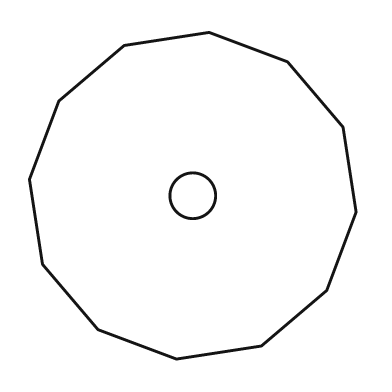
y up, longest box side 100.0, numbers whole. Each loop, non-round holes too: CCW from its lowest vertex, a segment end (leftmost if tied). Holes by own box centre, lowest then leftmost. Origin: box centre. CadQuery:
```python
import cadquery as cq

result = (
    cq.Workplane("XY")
    .moveTo(-5.0, -50.0)
    .lineTo(21.0, -46.0)
    .lineTo(41.0, -29.0)
    .lineTo(50.0, -5.0)
    .lineTo(46.0, 21.0)
    .lineTo(29.0, 41.0)
    .lineTo(5.0, 50.0)
    .lineTo(-21.0, 46.0)
    .lineTo(-41.0, 29.0)
    .lineTo(-50.0, 5.0)
    .lineTo(-46.0, -21.0)
    .lineTo(-29.0, -41.0)
    .close()
    .moveTo(0.0, 0.0)
    .circle(7.0)
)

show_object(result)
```